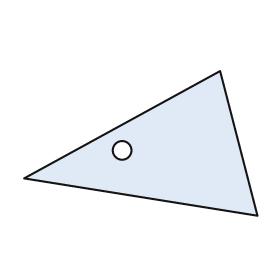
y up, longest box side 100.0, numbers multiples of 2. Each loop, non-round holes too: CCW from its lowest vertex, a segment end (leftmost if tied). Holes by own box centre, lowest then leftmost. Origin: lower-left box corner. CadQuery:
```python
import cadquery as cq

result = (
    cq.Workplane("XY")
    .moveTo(100.0, 0.0)
    .lineTo(84.0, 62.0)
    .lineTo(0.0, 16.0)
    .close()
    .moveTo(42.0, 28.0)
    .circle(4.0)
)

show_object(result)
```